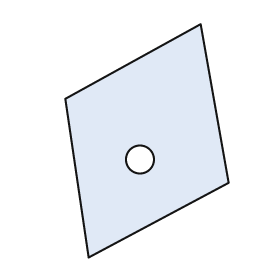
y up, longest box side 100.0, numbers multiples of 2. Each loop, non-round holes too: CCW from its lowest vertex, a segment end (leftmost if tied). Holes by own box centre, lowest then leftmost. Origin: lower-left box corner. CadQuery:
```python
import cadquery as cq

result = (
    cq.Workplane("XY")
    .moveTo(10.0, 0.0)
    .lineTo(70.0, 32.0)
    .lineTo(58.0, 100.0)
    .lineTo(0.0, 68.0)
    .close()
    .moveTo(32.0, 42.0)
    .circle(6.0)
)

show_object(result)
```